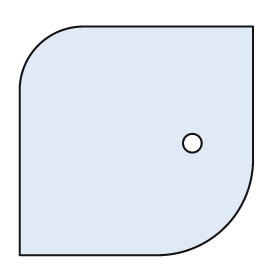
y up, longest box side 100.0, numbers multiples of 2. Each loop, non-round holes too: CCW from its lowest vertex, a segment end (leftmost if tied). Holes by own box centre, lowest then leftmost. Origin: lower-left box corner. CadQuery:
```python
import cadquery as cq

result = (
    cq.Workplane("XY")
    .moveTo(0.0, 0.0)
    .lineTo(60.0, 0.0)
    .threePointArc((88.0, 12.0), (100.0, 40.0))
    .lineTo(100.0, 98.0)
    .lineTo(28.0, 98.0)
    .threePointArc((8.0, 90.0), (0.0, 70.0))
    .close()
    .moveTo(74.0, 48.0)
    .circle(4.0)
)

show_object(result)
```